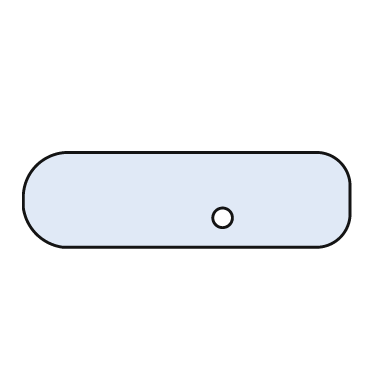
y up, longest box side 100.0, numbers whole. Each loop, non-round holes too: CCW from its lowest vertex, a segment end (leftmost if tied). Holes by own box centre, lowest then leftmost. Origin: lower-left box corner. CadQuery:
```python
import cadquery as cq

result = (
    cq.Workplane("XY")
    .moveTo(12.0, 0.0)
    .lineTo(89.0, 0.0)
    .threePointArc((97.0, 3.0), (100.0, 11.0))
    .lineTo(100.0, 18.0)
    .threePointArc((97.0, 26.0), (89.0, 29.0))
    .lineTo(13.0, 29.0)
    .threePointArc((4.0, 25.0), (0.0, 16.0))
    .lineTo(0.0, 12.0)
    .threePointArc((4.0, 4.0), (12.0, 0.0))
    .close()
    .moveTo(61.0, 9.0)
    .circle(3.0)
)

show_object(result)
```